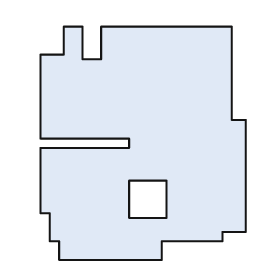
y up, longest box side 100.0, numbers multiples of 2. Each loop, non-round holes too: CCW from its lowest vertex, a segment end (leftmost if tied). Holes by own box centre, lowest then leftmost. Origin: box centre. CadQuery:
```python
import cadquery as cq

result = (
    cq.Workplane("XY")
    .moveTo(-36.0, -50.0)
    .lineTo(8.0, -50.0)
    .lineTo(8.0, -42.0)
    .lineTo(34.0, -42.0)
    .lineTo(34.0, -38.0)
    .lineTo(44.0, -38.0)
    .lineTo(44.0, 10.0)
    .lineTo(38.0, 10.0)
    .lineTo(38.0, 50.0)
    .lineTo(-18.0, 50.0)
    .lineTo(-18.0, 36.0)
    .lineTo(-26.0, 36.0)
    .lineTo(-26.0, 50.0)
    .lineTo(-34.0, 50.0)
    .lineTo(-34.0, 38.0)
    .lineTo(-44.0, 38.0)
    .lineTo(-44.0, 2.0)
    .lineTo(-6.0, 2.0)
    .lineTo(-6.0, -2.0)
    .lineTo(-44.0, -2.0)
    .lineTo(-44.0, -30.0)
    .lineTo(-40.0, -30.0)
    .lineTo(-40.0, -42.0)
    .lineTo(-36.0, -42.0)
    .close()
    .moveTo(-6.0, -32.0)
    .lineTo(10.0, -32.0)
    .lineTo(10.0, -16.0)
    .lineTo(-6.0, -16.0)
    .close()
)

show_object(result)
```